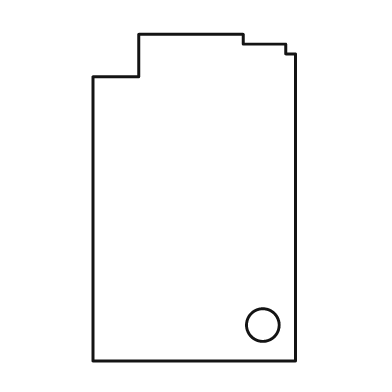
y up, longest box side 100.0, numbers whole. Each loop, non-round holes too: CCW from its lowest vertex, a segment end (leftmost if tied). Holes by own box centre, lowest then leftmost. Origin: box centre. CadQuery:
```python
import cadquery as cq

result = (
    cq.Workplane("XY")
    .moveTo(-31.0, -50.0)
    .lineTo(31.0, -50.0)
    .lineTo(31.0, 44.0)
    .lineTo(28.0, 44.0)
    .lineTo(28.0, 47.0)
    .lineTo(15.0, 47.0)
    .lineTo(15.0, 50.0)
    .lineTo(-17.0, 50.0)
    .lineTo(-17.0, 37.0)
    .lineTo(-31.0, 37.0)
    .close()
    .moveTo(21.0, -39.0)
    .circle(5.0)
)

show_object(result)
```